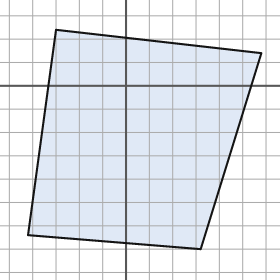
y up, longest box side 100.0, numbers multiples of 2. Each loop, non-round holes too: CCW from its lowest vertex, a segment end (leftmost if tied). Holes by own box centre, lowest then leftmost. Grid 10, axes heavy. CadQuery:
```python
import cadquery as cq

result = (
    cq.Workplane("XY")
    .moveTo(32.0, -70.0)
    .lineTo(58.0, 14.0)
    .lineTo(-30.0, 24.0)
    .lineTo(-42.0, -64.0)
    .close()
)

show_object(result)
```